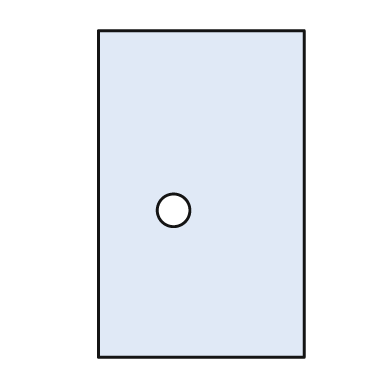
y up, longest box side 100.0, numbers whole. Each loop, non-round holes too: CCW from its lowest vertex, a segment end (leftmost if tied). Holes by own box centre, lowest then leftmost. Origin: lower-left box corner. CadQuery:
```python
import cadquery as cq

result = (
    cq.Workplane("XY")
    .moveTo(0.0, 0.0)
    .lineTo(63.0, 0.0)
    .lineTo(63.0, 100.0)
    .lineTo(0.0, 100.0)
    .close()
    .moveTo(23.0, 45.0)
    .circle(5.0)
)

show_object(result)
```